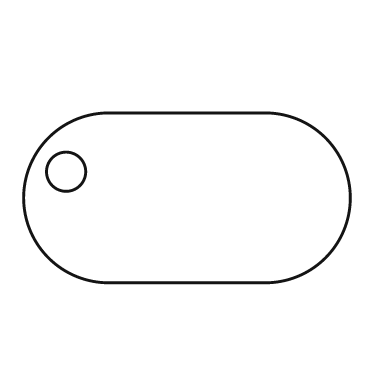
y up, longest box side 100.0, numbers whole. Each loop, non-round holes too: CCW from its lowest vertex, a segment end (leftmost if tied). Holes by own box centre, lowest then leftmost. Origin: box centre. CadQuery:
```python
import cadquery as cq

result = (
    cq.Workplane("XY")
    .moveTo(-24.0, -26.0)
    .lineTo(24.0, -26.0)
    .threePointArc((50.0, 0.0), (24.0, 26.0))
    .lineTo(-24.0, 26.0)
    .threePointArc((-50.0, 0.0), (-24.0, -26.0))
    .close()
    .moveTo(-37.0, 8.0)
    .circle(6.0)
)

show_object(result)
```